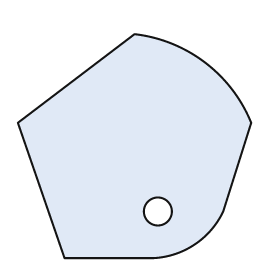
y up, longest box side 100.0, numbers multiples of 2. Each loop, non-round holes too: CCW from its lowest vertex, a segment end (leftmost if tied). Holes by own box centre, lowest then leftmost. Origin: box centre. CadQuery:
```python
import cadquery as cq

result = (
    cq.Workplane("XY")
    .moveTo(-30.0, -48.0)
    .lineTo(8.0, -48.0)
    .threePointArc((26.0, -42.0), (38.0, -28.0))
    .lineTo(50.0, 10.0)
    .threePointArc((30.0, 36.0), (0.0, 48.0))
    .lineTo(-50.0, 10.0)
    .close()
    .moveTo(10.0, -28.0)
    .circle(6.0)
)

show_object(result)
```